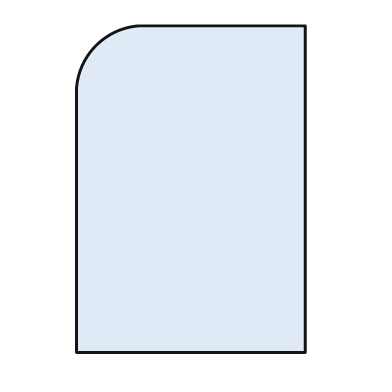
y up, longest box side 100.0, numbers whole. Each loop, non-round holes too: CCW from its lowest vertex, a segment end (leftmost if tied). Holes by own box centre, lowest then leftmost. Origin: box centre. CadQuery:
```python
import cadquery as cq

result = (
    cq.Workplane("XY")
    .moveTo(-35.0, -50.0)
    .lineTo(35.0, -50.0)
    .lineTo(35.0, 50.0)
    .lineTo(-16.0, 50.0)
    .threePointArc((-29.0, 44.0), (-35.0, 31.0))
    .close()
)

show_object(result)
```